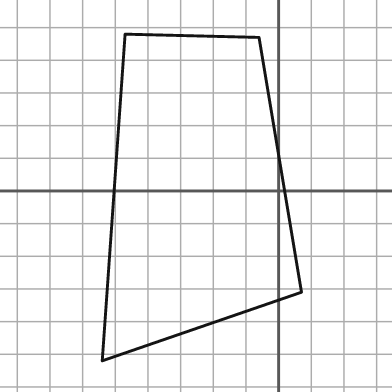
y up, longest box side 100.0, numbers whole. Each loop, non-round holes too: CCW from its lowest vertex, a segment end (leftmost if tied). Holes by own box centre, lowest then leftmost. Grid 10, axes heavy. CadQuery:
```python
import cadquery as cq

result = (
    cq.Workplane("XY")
    .moveTo(-54.0, -52.0)
    .lineTo(7.0, -31.0)
    .lineTo(-6.0, 47.0)
    .lineTo(-47.0, 48.0)
    .close()
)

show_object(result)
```